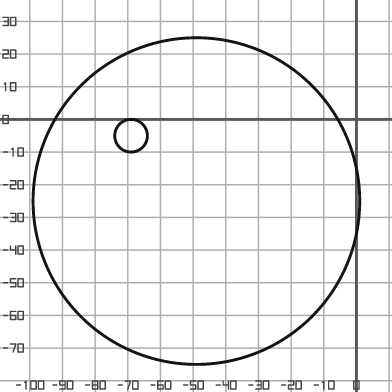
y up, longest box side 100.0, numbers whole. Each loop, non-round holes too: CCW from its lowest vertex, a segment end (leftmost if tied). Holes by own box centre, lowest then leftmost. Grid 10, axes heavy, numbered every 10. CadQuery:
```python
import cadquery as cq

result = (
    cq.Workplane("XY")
    .moveTo(-49.0, -25.0)
    .circle(50.0)
    .moveTo(-69.0, -5.0)
    .circle(5.0)
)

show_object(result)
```